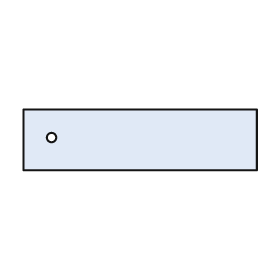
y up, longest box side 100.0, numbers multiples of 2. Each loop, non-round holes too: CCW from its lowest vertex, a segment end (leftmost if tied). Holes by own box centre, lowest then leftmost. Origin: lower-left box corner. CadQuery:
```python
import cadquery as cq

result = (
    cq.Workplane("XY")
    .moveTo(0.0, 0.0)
    .lineTo(100.0, 0.0)
    .lineTo(100.0, 26.0)
    .lineTo(0.0, 26.0)
    .close()
    .moveTo(12.0, 14.0)
    .circle(2.0)
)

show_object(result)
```